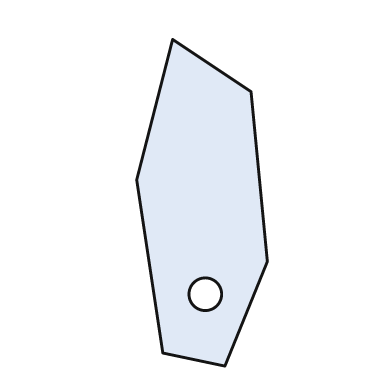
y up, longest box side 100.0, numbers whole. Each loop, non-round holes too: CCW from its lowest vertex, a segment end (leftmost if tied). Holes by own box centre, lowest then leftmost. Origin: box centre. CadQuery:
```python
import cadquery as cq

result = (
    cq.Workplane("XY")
    .moveTo(7.0, -50.0)
    .lineTo(20.0, -18.0)
    .lineTo(15.0, 34.0)
    .lineTo(-9.0, 50.0)
    .lineTo(-20.0, 7.0)
    .lineTo(-12.0, -46.0)
    .close()
    .moveTo(1.0, -28.0)
    .circle(5.0)
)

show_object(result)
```